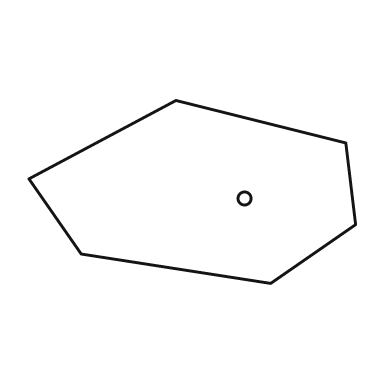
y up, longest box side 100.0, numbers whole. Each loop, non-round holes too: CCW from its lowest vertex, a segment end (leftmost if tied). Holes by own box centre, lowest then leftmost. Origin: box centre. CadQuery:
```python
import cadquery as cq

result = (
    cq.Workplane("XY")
    .moveTo(24.0, -28.0)
    .lineTo(50.0, -10.0)
    .lineTo(47.0, 15.0)
    .lineTo(-5.0, 28.0)
    .lineTo(-50.0, 4.0)
    .lineTo(-34.0, -19.0)
    .close()
    .moveTo(16.0, -2.0)
    .circle(2.0)
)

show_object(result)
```